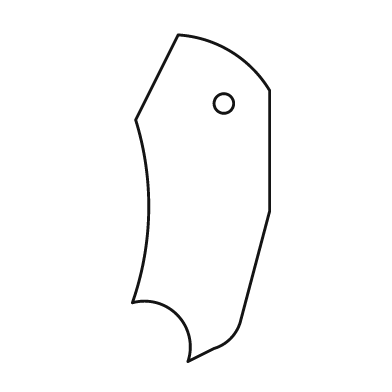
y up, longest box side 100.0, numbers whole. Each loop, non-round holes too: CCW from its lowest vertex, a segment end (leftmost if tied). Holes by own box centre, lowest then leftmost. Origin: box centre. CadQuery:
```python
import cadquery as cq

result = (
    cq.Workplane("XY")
    .moveTo(-4.0, -50.0)
    .lineTo(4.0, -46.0)
    .threePointArc((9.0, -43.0), (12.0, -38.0))
    .lineTo(21.0, -4.0)
    .lineTo(21.0, 33.0)
    .threePointArc((9.0, 45.0), (-7.0, 50.0))
    .lineTo(-20.0, 24.0)
    .threePointArc((-16.0, -4.0), (-21.0, -32.0))
    .threePointArc((-7.0, -36.0), (-4.0, -50.0))
    .close()
    .moveTo(7.0, 29.0)
    .circle(3.0)
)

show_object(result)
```